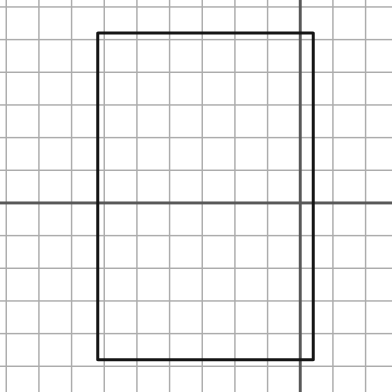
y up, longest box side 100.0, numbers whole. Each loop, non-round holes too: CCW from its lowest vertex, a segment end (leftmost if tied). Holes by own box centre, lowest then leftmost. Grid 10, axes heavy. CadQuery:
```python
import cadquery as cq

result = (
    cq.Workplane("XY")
    .moveTo(-62.0, -48.0)
    .lineTo(4.0, -48.0)
    .lineTo(4.0, 52.0)
    .lineTo(-62.0, 52.0)
    .close()
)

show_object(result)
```